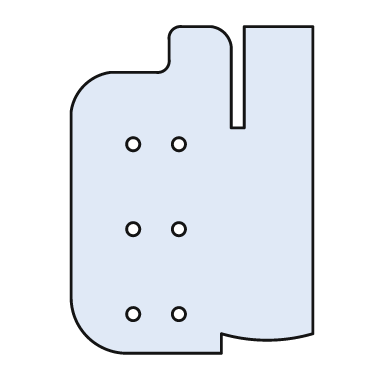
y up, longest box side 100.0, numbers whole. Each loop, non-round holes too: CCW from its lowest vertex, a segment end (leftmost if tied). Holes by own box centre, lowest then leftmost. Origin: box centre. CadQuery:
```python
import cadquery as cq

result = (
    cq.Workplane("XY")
    .moveTo(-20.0, -50.0)
    .lineTo(9.0, -50.0)
    .lineTo(9.0, -44.0)
    .threePointArc((23.0, -46.0), (37.0, -44.0))
    .lineTo(37.0, 50.0)
    .lineTo(16.0, 50.0)
    .lineTo(16.0, 19.0)
    .lineTo(12.0, 19.0)
    .lineTo(12.0, 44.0)
    .threePointArc((10.0, 48.0), (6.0, 50.0))
    .lineTo(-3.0, 50.0)
    .threePointArc((-6.0, 49.0), (-7.0, 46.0))
    .lineTo(-7.0, 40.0)
    .threePointArc((-8.0, 37.0), (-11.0, 36.0))
    .lineTo(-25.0, 36.0)
    .threePointArc((-33.0, 32.0), (-37.0, 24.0))
    .lineTo(-37.0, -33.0)
    .threePointArc((-32.0, -45.0), (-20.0, -50.0))
    .close()
    .moveTo(-18.0, -38.0)
    .circle(2.0)
    .moveTo(-4.0, -38.0)
    .circle(2.0)
    .moveTo(-18.0, -12.0)
    .circle(2.0)
    .moveTo(-4.0, -12.0)
    .circle(2.0)
    .moveTo(-18.0, 14.0)
    .circle(2.0)
    .moveTo(-4.0, 14.0)
    .circle(2.0)
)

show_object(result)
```